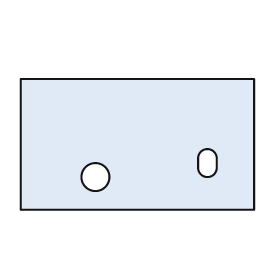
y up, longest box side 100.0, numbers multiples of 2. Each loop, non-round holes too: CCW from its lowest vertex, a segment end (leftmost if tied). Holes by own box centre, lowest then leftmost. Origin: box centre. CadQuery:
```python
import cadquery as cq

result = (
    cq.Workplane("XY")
    .moveTo(-50.0, -28.0)
    .lineTo(50.0, -28.0)
    .lineTo(50.0, 28.0)
    .lineTo(-50.0, 28.0)
    .close()
    .moveTo(-18.0, -14.0)
    .circle(6.0)
    .moveTo(26.0, -10.0)
    .threePointArc((30.0, -14.0), (34.0, -10.0))
    .lineTo(34.0, -6.0)
    .threePointArc((30.0, -2.0), (26.0, -6.0))
    .close()
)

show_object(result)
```